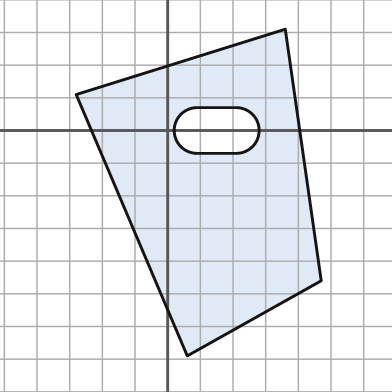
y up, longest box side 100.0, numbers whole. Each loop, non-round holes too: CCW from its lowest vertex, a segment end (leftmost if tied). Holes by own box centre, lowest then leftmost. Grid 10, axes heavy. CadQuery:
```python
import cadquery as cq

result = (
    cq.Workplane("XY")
    .moveTo(6.0, -69.0)
    .lineTo(47.0, -46.0)
    .lineTo(36.0, 31.0)
    .lineTo(-28.0, 11.0)
    .close()
    .moveTo(9.0, -7.0)
    .lineTo(21.0, -7.0)
    .threePointArc((28.0, 0.0), (21.0, 7.0))
    .lineTo(9.0, 7.0)
    .threePointArc((2.0, 0.0), (9.0, -7.0))
    .close()
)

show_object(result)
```